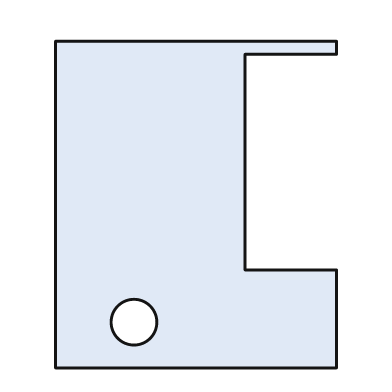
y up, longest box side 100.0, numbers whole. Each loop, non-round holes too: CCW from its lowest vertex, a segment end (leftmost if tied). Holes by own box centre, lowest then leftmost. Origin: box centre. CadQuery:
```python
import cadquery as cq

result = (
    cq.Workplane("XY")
    .moveTo(-43.0, -50.0)
    .lineTo(43.0, -50.0)
    .lineTo(43.0, -20.0)
    .lineTo(15.0, -20.0)
    .lineTo(15.0, 46.0)
    .lineTo(43.0, 46.0)
    .lineTo(43.0, 50.0)
    .lineTo(-43.0, 50.0)
    .close()
    .moveTo(-19.0, -36.0)
    .circle(7.0)
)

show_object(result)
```